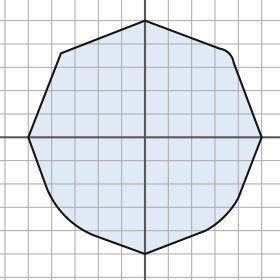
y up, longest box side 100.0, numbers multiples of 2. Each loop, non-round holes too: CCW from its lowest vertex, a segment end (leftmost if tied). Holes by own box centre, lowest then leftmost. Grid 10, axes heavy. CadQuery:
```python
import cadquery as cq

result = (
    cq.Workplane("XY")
    .moveTo(0.0, -50.0)
    .lineTo(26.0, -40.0)
    .threePointArc((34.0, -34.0), (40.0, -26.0))
    .lineTo(50.0, 0.0)
    .lineTo(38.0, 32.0)
    .threePointArc((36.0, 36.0), (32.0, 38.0))
    .lineTo(0.0, 50.0)
    .lineTo(-36.0, 36.0)
    .lineTo(-50.0, 0.0)
    .lineTo(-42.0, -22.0)
    .threePointArc((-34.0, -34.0), (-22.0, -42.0))
    .close()
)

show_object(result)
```